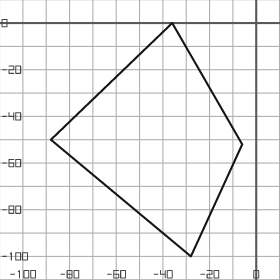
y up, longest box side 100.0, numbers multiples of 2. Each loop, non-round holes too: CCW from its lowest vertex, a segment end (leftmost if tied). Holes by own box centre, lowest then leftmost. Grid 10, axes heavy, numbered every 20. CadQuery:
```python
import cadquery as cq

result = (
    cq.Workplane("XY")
    .moveTo(-28.0, -100.0)
    .lineTo(-6.0, -52.0)
    .lineTo(-36.0, 0.0)
    .lineTo(-88.0, -50.0)
    .close()
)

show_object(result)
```